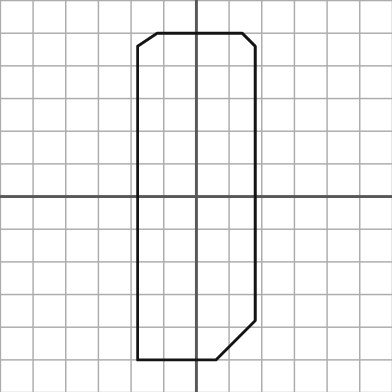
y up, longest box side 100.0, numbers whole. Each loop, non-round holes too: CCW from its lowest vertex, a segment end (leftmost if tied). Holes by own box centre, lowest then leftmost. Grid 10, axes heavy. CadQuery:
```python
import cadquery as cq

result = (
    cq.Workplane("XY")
    .moveTo(-18.0, -50.0)
    .lineTo(6.0, -50.0)
    .lineTo(18.0, -38.0)
    .lineTo(18.0, 46.0)
    .lineTo(14.0, 50.0)
    .lineTo(-12.0, 50.0)
    .lineTo(-18.0, 46.0)
    .close()
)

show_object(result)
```